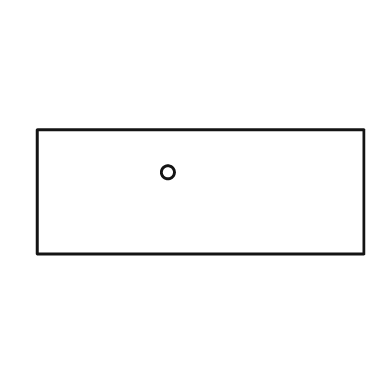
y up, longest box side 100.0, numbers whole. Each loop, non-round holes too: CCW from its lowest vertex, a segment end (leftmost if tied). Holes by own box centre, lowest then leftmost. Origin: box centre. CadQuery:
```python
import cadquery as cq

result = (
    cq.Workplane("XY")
    .moveTo(-50.0, -19.0)
    .lineTo(50.0, -19.0)
    .lineTo(50.0, 19.0)
    .lineTo(-50.0, 19.0)
    .close()
    .moveTo(-10.0, 6.0)
    .circle(2.0)
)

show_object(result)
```